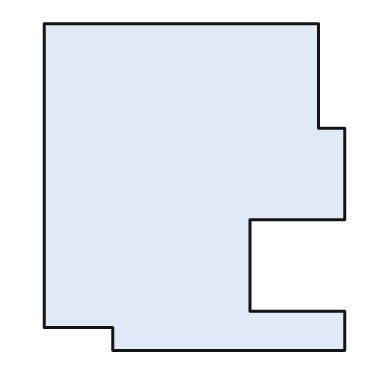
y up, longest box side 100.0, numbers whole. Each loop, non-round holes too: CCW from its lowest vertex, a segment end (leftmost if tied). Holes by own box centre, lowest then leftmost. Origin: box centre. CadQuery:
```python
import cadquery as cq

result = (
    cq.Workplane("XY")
    .moveTo(-25.0, -50.0)
    .lineTo(46.0, -50.0)
    .lineTo(46.0, -38.0)
    .lineTo(17.0, -38.0)
    .lineTo(17.0, -10.0)
    .lineTo(46.0, -10.0)
    .lineTo(46.0, 18.0)
    .lineTo(38.0, 18.0)
    .lineTo(38.0, 50.0)
    .lineTo(-46.0, 50.0)
    .lineTo(-46.0, -43.0)
    .lineTo(-25.0, -43.0)
    .close()
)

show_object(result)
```